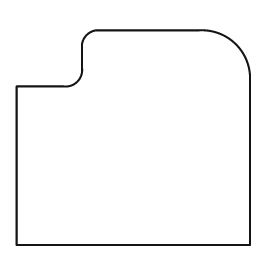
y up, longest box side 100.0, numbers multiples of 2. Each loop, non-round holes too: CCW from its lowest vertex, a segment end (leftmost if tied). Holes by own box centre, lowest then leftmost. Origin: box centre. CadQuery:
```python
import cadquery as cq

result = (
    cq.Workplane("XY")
    .moveTo(-50.0, -46.0)
    .lineTo(50.0, -46.0)
    .lineTo(50.0, 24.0)
    .threePointArc((44.0, 40.0), (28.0, 46.0))
    .lineTo(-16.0, 46.0)
    .threePointArc((-20.0, 44.0), (-22.0, 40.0))
    .lineTo(-22.0, 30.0)
    .threePointArc((-24.0, 24.0), (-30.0, 22.0))
    .lineTo(-50.0, 22.0)
    .close()
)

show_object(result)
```